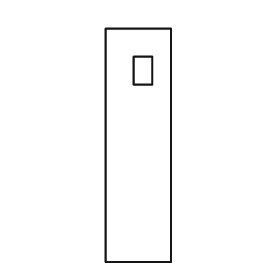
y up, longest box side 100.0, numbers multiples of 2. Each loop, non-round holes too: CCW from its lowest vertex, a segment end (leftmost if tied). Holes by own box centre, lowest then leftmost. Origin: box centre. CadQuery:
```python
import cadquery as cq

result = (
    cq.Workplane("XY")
    .moveTo(-14.0, -50.0)
    .lineTo(14.0, -50.0)
    .lineTo(14.0, 50.0)
    .lineTo(-14.0, 50.0)
    .close()
    .moveTo(-2.0, 26.0)
    .lineTo(6.0, 26.0)
    .lineTo(6.0, 38.0)
    .lineTo(-2.0, 38.0)
    .close()
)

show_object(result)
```